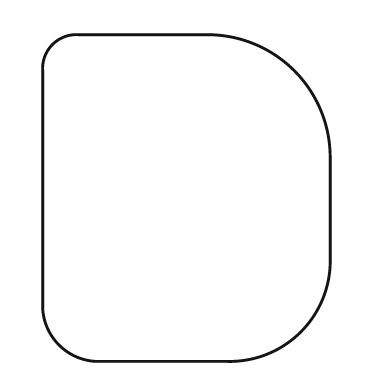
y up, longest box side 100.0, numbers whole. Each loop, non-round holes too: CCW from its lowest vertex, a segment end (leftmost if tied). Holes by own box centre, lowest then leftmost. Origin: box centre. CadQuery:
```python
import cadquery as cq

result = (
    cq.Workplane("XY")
    .moveTo(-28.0, -50.0)
    .lineTo(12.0, -50.0)
    .threePointArc((35.0, -41.0), (44.0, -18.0))
    .lineTo(44.0, 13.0)
    .threePointArc((33.0, 39.0), (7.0, 50.0))
    .lineTo(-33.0, 50.0)
    .threePointArc((-41.0, 47.0), (-44.0, 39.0))
    .lineTo(-44.0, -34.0)
    .threePointArc((-39.0, -45.0), (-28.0, -50.0))
    .close()
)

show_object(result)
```